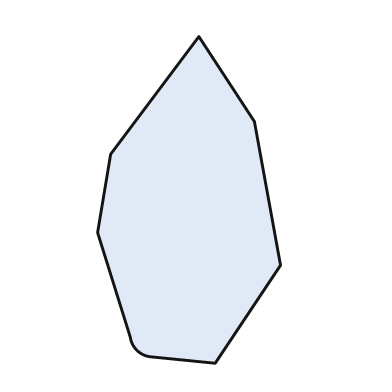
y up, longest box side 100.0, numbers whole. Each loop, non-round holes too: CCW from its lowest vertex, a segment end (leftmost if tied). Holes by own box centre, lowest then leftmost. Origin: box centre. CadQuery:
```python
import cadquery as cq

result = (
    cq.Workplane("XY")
    .moveTo(8.0, -50.0)
    .lineTo(28.0, -20.0)
    .lineTo(20.0, 24.0)
    .lineTo(3.0, 50.0)
    .lineTo(-24.0, 14.0)
    .lineTo(-28.0, -10.0)
    .lineTo(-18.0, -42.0)
    .threePointArc((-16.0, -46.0), (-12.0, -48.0))
    .close()
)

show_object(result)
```